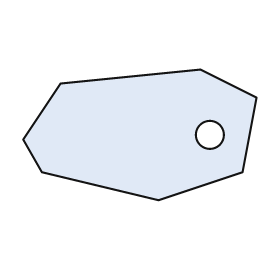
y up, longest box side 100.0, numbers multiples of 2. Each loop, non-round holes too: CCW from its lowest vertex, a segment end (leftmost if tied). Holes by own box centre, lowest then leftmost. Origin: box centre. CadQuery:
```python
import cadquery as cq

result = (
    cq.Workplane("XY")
    .moveTo(8.0, -28.0)
    .lineTo(44.0, -16.0)
    .lineTo(50.0, 16.0)
    .lineTo(26.0, 28.0)
    .lineTo(-34.0, 22.0)
    .lineTo(-50.0, -2.0)
    .lineTo(-42.0, -16.0)
    .close()
    .moveTo(30.0, 0.0)
    .circle(6.0)
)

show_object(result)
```